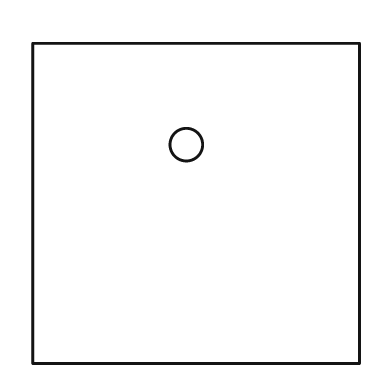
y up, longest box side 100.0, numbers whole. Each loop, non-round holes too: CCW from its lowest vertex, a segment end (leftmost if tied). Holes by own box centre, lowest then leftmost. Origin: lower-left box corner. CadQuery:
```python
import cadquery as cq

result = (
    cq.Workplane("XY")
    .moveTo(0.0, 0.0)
    .lineTo(100.0, 0.0)
    .lineTo(100.0, 98.0)
    .lineTo(0.0, 98.0)
    .close()
    .moveTo(47.0, 67.0)
    .circle(5.0)
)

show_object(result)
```